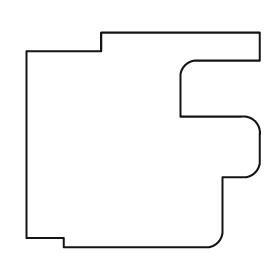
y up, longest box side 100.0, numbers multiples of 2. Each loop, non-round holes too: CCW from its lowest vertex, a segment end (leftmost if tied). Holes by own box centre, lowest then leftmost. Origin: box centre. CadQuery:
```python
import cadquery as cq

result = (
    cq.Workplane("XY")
    .moveTo(-34.0, -46.0)
    .lineTo(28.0, -46.0)
    .threePointArc((32.0, -44.0), (34.0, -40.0))
    .lineTo(34.0, -16.0)
    .lineTo(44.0, -16.0)
    .threePointArc((48.0, -14.0), (50.0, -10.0))
    .lineTo(50.0, 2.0)
    .threePointArc((48.0, 8.0), (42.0, 10.0))
    .lineTo(16.0, 10.0)
    .lineTo(16.0, 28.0)
    .threePointArc((18.0, 32.0), (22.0, 34.0))
    .lineTo(50.0, 34.0)
    .lineTo(50.0, 46.0)
    .lineTo(-18.0, 46.0)
    .lineTo(-18.0, 38.0)
    .lineTo(-50.0, 38.0)
    .lineTo(-50.0, -42.0)
    .lineTo(-34.0, -42.0)
    .close()
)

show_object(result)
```